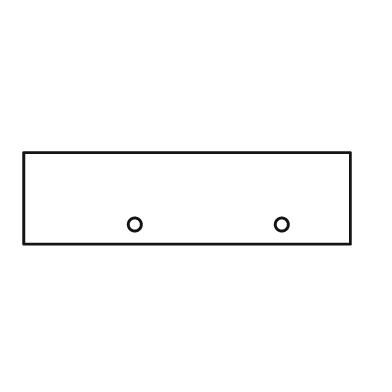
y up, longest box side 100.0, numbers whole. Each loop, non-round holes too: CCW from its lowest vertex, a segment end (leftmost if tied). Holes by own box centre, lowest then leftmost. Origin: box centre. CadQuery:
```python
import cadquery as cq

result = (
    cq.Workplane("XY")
    .moveTo(-50.0, -14.0)
    .lineTo(50.0, -14.0)
    .lineTo(50.0, 14.0)
    .lineTo(-50.0, 14.0)
    .close()
    .moveTo(-16.0, -8.0)
    .circle(2.0)
    .moveTo(29.0, -8.0)
    .circle(2.0)
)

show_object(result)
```